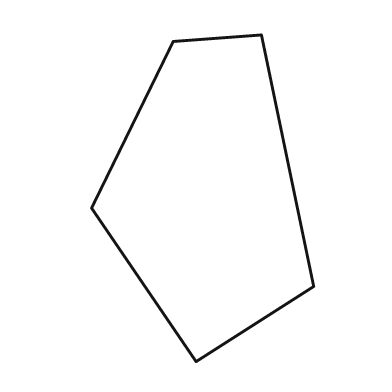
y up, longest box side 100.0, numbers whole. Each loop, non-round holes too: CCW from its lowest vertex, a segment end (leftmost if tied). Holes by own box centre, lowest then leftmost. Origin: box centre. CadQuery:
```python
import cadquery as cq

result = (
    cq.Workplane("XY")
    .moveTo(-2.0, -50.0)
    .lineTo(34.0, -27.0)
    .lineTo(18.0, 50.0)
    .lineTo(-9.0, 48.0)
    .lineTo(-34.0, -3.0)
    .close()
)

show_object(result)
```